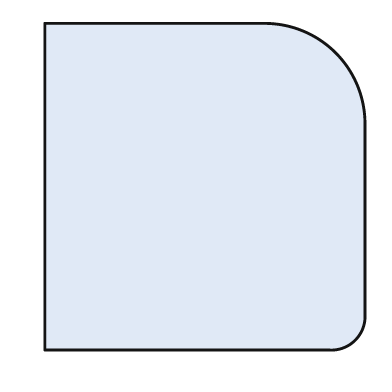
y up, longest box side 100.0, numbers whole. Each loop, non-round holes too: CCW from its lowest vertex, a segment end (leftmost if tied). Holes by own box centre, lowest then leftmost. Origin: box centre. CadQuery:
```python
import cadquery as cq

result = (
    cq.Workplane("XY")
    .moveTo(-49.0, -50.0)
    .lineTo(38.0, -50.0)
    .threePointArc((46.0, -47.0), (49.0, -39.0))
    .lineTo(49.0, 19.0)
    .threePointArc((40.0, 41.0), (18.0, 50.0))
    .lineTo(-49.0, 50.0)
    .close()
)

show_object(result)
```